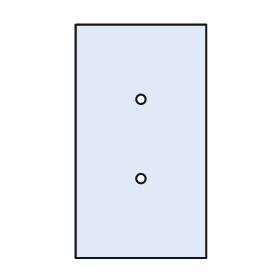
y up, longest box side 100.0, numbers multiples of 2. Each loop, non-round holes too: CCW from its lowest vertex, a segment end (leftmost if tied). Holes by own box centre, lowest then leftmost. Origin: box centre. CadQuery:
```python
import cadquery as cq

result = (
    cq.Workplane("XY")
    .moveTo(-28.0, -50.0)
    .lineTo(28.0, -50.0)
    .lineTo(28.0, 50.0)
    .lineTo(-28.0, 50.0)
    .close()
    .moveTo(0.0, -16.0)
    .circle(2.0)
    .moveTo(0.0, 18.0)
    .circle(2.0)
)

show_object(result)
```